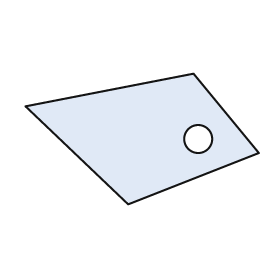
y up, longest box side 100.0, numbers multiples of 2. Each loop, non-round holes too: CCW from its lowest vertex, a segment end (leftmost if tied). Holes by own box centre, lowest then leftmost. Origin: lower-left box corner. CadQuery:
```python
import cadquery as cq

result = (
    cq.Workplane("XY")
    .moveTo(44.0, 0.0)
    .lineTo(100.0, 22.0)
    .lineTo(72.0, 56.0)
    .lineTo(0.0, 42.0)
    .close()
    .moveTo(74.0, 28.0)
    .circle(6.0)
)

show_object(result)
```